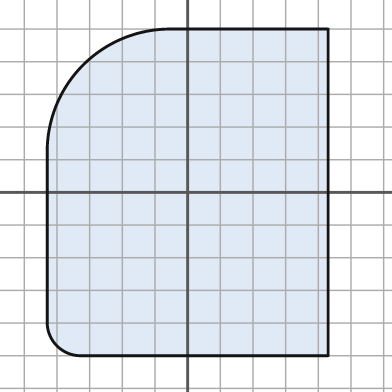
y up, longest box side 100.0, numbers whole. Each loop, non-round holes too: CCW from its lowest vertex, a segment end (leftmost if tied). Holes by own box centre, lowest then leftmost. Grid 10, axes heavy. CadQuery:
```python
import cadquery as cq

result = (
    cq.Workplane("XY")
    .moveTo(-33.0, -50.0)
    .lineTo(43.0, -50.0)
    .lineTo(43.0, 50.0)
    .lineTo(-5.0, 50.0)
    .threePointArc((-32.0, 39.0), (-43.0, 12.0))
    .lineTo(-43.0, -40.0)
    .threePointArc((-40.0, -47.0), (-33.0, -50.0))
    .close()
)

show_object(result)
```